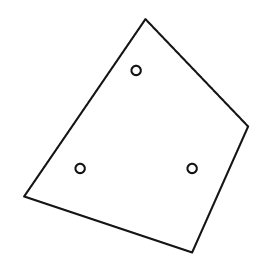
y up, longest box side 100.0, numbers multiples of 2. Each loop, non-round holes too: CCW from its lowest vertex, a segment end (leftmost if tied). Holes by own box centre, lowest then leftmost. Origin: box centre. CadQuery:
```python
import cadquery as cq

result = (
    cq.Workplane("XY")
    .moveTo(24.0, -50.0)
    .lineTo(48.0, 4.0)
    .lineTo(4.0, 50.0)
    .lineTo(-48.0, -26.0)
    .close()
    .moveTo(-24.0, -14.0)
    .circle(2.0)
    .moveTo(24.0, -14.0)
    .circle(2.0)
    .moveTo(0.0, 28.0)
    .circle(2.0)
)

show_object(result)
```